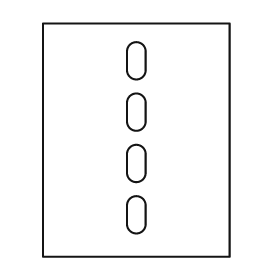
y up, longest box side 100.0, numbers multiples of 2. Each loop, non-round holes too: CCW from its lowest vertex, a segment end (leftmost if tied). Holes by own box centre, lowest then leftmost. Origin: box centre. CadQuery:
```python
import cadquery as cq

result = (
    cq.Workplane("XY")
    .moveTo(-40.0, -50.0)
    .lineTo(40.0, -50.0)
    .lineTo(40.0, 50.0)
    .lineTo(-40.0, 50.0)
    .close()
    .moveTo(-4.0, -36.0)
    .threePointArc((0.0, -40.0), (4.0, -36.0))
    .lineTo(4.0, -28.0)
    .threePointArc((0.0, -24.0), (-4.0, -28.0))
    .close()
    .moveTo(-4.0, -14.0)
    .threePointArc((0.0, -18.0), (4.0, -14.0))
    .lineTo(4.0, -6.0)
    .threePointArc((0.0, -2.0), (-4.0, -6.0))
    .close()
    .moveTo(-4.0, 8.0)
    .threePointArc((0.0, 4.0), (4.0, 8.0))
    .lineTo(4.0, 16.0)
    .threePointArc((0.0, 20.0), (-4.0, 16.0))
    .close()
    .moveTo(-4.0, 30.0)
    .threePointArc((0.0, 26.0), (4.0, 30.0))
    .lineTo(4.0, 38.0)
    .threePointArc((0.0, 42.0), (-4.0, 38.0))
    .close()
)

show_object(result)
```